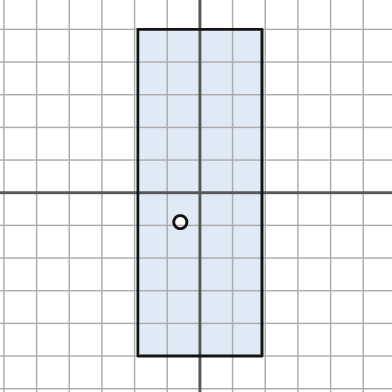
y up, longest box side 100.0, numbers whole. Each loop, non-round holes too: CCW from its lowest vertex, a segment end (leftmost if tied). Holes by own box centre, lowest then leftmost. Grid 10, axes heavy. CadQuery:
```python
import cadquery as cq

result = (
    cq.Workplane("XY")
    .moveTo(-19.0, -50.0)
    .lineTo(19.0, -50.0)
    .lineTo(19.0, 50.0)
    .lineTo(-19.0, 50.0)
    .close()
    .moveTo(-6.0, -9.0)
    .circle(2.0)
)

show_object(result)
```